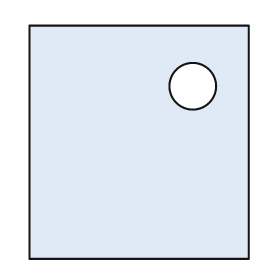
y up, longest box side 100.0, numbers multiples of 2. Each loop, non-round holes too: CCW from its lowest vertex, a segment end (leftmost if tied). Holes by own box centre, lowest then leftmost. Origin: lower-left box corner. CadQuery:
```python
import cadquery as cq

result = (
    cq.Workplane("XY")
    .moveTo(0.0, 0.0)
    .lineTo(94.0, 0.0)
    .lineTo(94.0, 100.0)
    .lineTo(0.0, 100.0)
    .close()
    .moveTo(70.0, 74.0)
    .circle(10.0)
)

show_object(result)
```